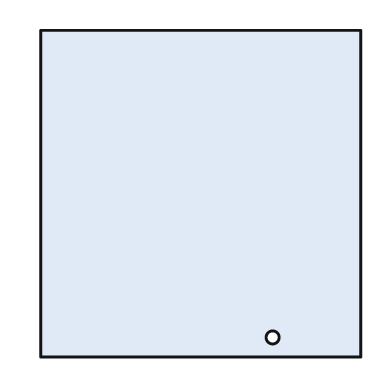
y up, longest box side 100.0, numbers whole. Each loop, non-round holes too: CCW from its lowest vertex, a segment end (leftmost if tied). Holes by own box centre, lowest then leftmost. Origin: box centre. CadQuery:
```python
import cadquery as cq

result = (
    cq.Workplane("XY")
    .moveTo(-49.0, -50.0)
    .lineTo(49.0, -50.0)
    .lineTo(49.0, 50.0)
    .lineTo(-49.0, 50.0)
    .close()
    .moveTo(22.0, -44.0)
    .circle(2.0)
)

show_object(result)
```